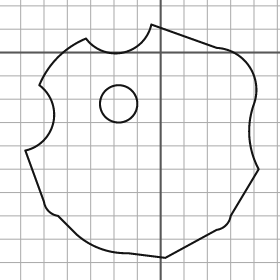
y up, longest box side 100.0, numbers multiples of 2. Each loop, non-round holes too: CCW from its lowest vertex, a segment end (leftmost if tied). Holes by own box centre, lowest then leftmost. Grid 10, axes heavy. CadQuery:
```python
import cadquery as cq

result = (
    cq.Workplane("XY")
    .moveTo(2.0, -88.0)
    .lineTo(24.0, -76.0)
    .threePointArc((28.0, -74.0), (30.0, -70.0))
    .lineTo(42.0, -50.0)
    .threePointArc((38.0, -36.0), (40.0, -22.0))
    .threePointArc((38.0, -6.0), (24.0, 2.0))
    .lineTo(-4.0, 12.0)
    .threePointArc((-16.0, 0.0), (-32.0, 6.0))
    .threePointArc((-44.0, -2.0), (-52.0, -14.0))
    .threePointArc((-46.0, -30.0), (-58.0, -42.0))
    .lineTo(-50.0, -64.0)
    .threePointArc((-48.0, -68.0), (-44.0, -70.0))
    .lineTo(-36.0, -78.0)
    .threePointArc((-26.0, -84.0), (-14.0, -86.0))
    .close()
    .moveTo(-18.0, -22.0)
    .circle(8.0)
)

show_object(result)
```